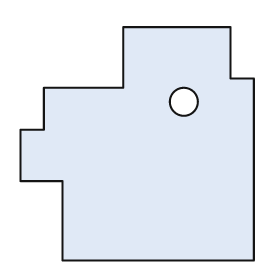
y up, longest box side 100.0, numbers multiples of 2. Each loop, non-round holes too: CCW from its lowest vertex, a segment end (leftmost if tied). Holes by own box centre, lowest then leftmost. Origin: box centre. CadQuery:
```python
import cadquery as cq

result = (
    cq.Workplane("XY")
    .moveTo(-32.0, -50.0)
    .lineTo(50.0, -50.0)
    .lineTo(50.0, 28.0)
    .lineTo(40.0, 28.0)
    .lineTo(40.0, 50.0)
    .lineTo(-6.0, 50.0)
    .lineTo(-6.0, 24.0)
    .lineTo(-40.0, 24.0)
    .lineTo(-40.0, 6.0)
    .lineTo(-50.0, 6.0)
    .lineTo(-50.0, -16.0)
    .lineTo(-32.0, -16.0)
    .close()
    .moveTo(20.0, 18.0)
    .circle(6.0)
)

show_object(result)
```